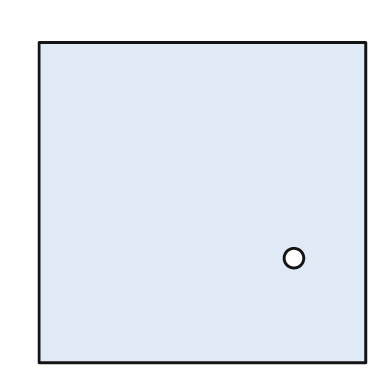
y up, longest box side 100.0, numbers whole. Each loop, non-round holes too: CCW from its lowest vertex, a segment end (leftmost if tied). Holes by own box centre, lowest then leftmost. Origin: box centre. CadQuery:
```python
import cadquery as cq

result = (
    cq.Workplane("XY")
    .moveTo(-50.0, -49.0)
    .lineTo(50.0, -49.0)
    .lineTo(50.0, 49.0)
    .lineTo(-50.0, 49.0)
    .close()
    .moveTo(28.0, -17.0)
    .circle(3.0)
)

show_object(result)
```